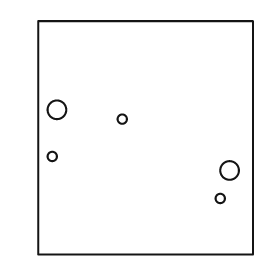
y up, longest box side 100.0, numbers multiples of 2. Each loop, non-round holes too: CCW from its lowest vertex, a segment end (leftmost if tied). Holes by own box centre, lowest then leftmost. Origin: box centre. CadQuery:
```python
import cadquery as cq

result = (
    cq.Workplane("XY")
    .moveTo(-46.0, -50.0)
    .lineTo(46.0, -50.0)
    .lineTo(46.0, 50.0)
    .lineTo(-46.0, 50.0)
    .close()
    .moveTo(32.0, -26.0)
    .circle(2.0)
    .moveTo(36.0, -14.0)
    .circle(4.0)
    .moveTo(-40.0, -8.0)
    .circle(2.0)
    .moveTo(-10.0, 8.0)
    .circle(2.0)
    .moveTo(-38.0, 12.0)
    .circle(4.0)
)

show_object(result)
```